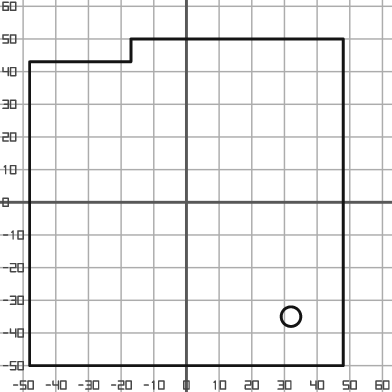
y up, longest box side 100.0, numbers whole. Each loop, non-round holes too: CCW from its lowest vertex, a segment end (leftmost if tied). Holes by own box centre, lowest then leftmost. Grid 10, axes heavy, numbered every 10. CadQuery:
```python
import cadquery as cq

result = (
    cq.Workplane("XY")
    .moveTo(-48.0, -50.0)
    .lineTo(48.0, -50.0)
    .lineTo(48.0, 50.0)
    .lineTo(-17.0, 50.0)
    .lineTo(-17.0, 43.0)
    .lineTo(-48.0, 43.0)
    .close()
    .moveTo(32.0, -35.0)
    .circle(3.0)
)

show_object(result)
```